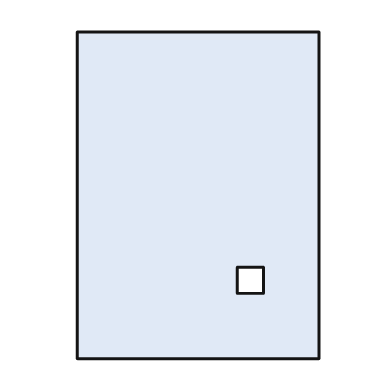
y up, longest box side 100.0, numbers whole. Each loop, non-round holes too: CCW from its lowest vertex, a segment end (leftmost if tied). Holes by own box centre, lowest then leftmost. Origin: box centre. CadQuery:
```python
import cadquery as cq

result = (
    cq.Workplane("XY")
    .moveTo(-37.0, -50.0)
    .lineTo(37.0, -50.0)
    .lineTo(37.0, 50.0)
    .lineTo(-37.0, 50.0)
    .close()
    .moveTo(12.0, -30.0)
    .lineTo(20.0, -30.0)
    .lineTo(20.0, -22.0)
    .lineTo(12.0, -22.0)
    .close()
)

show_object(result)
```